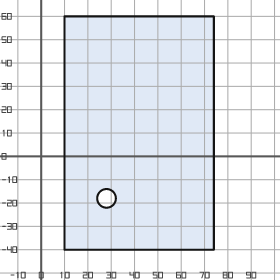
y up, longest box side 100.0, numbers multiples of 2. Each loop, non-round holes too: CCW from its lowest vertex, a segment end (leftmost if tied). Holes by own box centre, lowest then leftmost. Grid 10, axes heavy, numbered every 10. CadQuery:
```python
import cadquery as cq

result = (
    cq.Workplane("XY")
    .moveTo(10.0, -40.0)
    .lineTo(74.0, -40.0)
    .lineTo(74.0, 60.0)
    .lineTo(10.0, 60.0)
    .close()
    .moveTo(28.0, -18.0)
    .circle(4.0)
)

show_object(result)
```